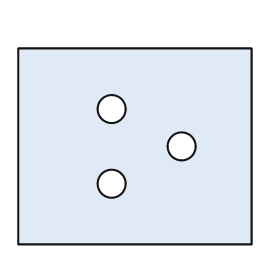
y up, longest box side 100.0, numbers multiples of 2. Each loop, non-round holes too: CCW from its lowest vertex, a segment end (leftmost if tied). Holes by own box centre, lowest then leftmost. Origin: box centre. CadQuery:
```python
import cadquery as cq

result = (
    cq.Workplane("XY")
    .moveTo(-50.0, -42.0)
    .lineTo(50.0, -42.0)
    .lineTo(50.0, 42.0)
    .lineTo(-50.0, 42.0)
    .close()
    .moveTo(-10.0, -16.0)
    .circle(6.0)
    .moveTo(20.0, 0.0)
    .circle(6.0)
    .moveTo(-10.0, 16.0)
    .circle(6.0)
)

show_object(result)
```